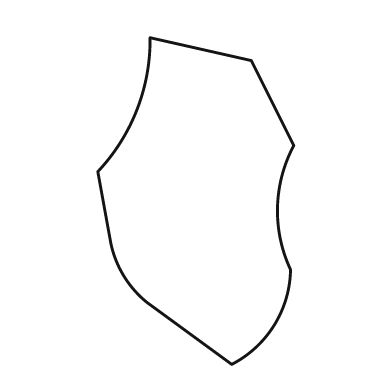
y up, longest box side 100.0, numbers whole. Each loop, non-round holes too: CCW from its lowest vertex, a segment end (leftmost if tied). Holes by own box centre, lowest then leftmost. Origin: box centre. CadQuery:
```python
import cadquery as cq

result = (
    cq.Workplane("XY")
    .moveTo(11.0, -50.0)
    .threePointArc((24.0, -38.0), (29.0, -21.0))
    .threePointArc((25.0, -2.0), (30.0, 17.0))
    .lineTo(17.0, 43.0)
    .lineTo(-14.0, 50.0)
    .threePointArc((-18.0, 28.0), (-30.0, 9.0))
    .lineTo(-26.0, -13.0)
    .threePointArc((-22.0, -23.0), (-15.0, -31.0))
    .close()
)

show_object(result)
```